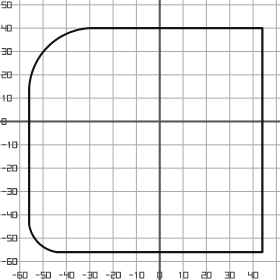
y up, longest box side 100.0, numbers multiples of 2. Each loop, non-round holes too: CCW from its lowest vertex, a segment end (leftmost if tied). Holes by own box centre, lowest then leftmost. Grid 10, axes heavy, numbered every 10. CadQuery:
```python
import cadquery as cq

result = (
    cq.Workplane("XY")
    .moveTo(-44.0, -56.0)
    .lineTo(44.0, -56.0)
    .lineTo(44.0, 40.0)
    .lineTo(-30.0, 40.0)
    .threePointArc((-48.0, 32.0), (-56.0, 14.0))
    .lineTo(-56.0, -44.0)
    .threePointArc((-52.0, -52.0), (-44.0, -56.0))
    .close()
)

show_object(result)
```